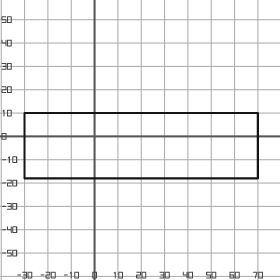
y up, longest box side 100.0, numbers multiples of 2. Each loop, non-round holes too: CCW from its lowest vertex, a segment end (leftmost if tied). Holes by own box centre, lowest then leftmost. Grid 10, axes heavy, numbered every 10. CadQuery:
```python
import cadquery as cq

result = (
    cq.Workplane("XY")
    .moveTo(-30.0, -18.0)
    .lineTo(70.0, -18.0)
    .lineTo(70.0, 10.0)
    .lineTo(-30.0, 10.0)
    .close()
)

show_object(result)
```